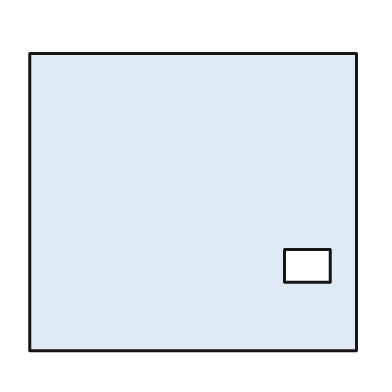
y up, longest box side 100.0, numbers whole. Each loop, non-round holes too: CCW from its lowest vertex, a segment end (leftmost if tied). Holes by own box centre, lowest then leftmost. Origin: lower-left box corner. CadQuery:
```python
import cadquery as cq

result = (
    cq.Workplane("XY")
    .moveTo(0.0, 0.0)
    .lineTo(100.0, 0.0)
    .lineTo(100.0, 91.0)
    .lineTo(0.0, 91.0)
    .close()
    .moveTo(78.0, 21.0)
    .lineTo(92.0, 21.0)
    .lineTo(92.0, 31.0)
    .lineTo(78.0, 31.0)
    .close()
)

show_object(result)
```